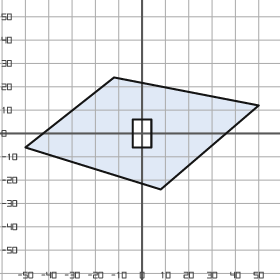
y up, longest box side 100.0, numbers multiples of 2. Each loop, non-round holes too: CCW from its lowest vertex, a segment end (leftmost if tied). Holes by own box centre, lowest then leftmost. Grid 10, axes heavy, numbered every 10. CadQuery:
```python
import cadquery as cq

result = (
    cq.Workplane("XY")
    .moveTo(8.0, -24.0)
    .lineTo(50.0, 12.0)
    .lineTo(-12.0, 24.0)
    .lineTo(-50.0, -6.0)
    .close()
    .moveTo(-4.0, -6.0)
    .lineTo(4.0, -6.0)
    .lineTo(4.0, 6.0)
    .lineTo(-4.0, 6.0)
    .close()
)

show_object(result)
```